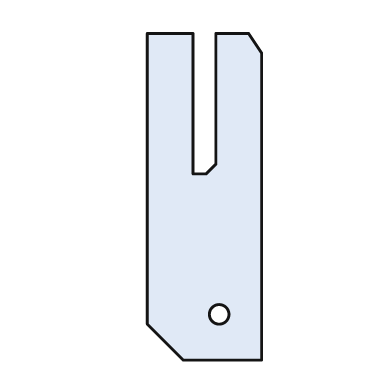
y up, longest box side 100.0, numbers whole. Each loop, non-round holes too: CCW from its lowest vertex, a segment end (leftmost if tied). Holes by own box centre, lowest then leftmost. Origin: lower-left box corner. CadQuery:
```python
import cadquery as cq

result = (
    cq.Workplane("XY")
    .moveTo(11.0, 0.0)
    .lineTo(35.0, 0.0)
    .lineTo(35.0, 94.0)
    .lineTo(31.0, 100.0)
    .lineTo(21.0, 100.0)
    .lineTo(21.0, 60.0)
    .lineTo(18.0, 57.0)
    .lineTo(14.0, 57.0)
    .lineTo(14.0, 100.0)
    .lineTo(0.0, 100.0)
    .lineTo(0.0, 11.0)
    .close()
    .moveTo(22.0, 14.0)
    .circle(3.0)
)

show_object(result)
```